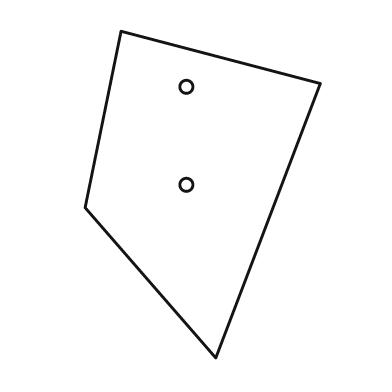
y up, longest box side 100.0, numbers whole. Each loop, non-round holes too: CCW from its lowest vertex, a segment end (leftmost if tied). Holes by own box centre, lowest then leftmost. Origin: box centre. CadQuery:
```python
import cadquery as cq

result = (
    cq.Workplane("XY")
    .moveTo(4.0, -50.0)
    .lineTo(36.0, 34.0)
    .lineTo(-25.0, 50.0)
    .lineTo(-36.0, -4.0)
    .close()
    .moveTo(-5.0, 3.0)
    .circle(2.0)
    .moveTo(-5.0, 33.0)
    .circle(2.0)
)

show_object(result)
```